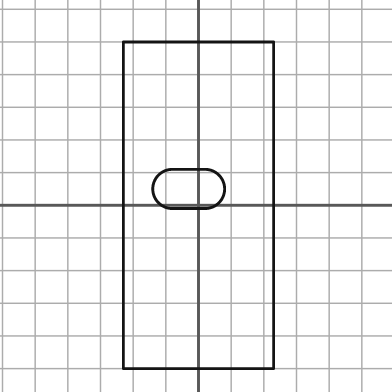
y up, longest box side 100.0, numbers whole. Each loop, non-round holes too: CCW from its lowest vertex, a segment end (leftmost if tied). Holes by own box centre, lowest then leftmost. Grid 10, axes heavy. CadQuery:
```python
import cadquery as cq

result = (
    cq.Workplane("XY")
    .moveTo(-23.0, -50.0)
    .lineTo(23.0, -50.0)
    .lineTo(23.0, 50.0)
    .lineTo(-23.0, 50.0)
    .close()
    .moveTo(-8.0, -1.0)
    .lineTo(2.0, -1.0)
    .threePointArc((8.0, 5.0), (2.0, 11.0))
    .lineTo(-8.0, 11.0)
    .threePointArc((-14.0, 5.0), (-8.0, -1.0))
    .close()
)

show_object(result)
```